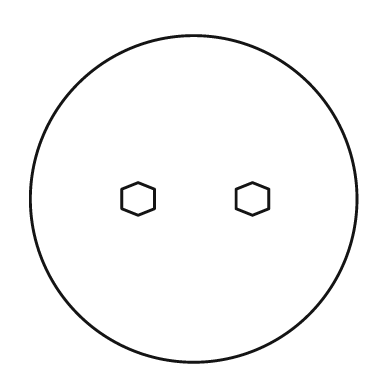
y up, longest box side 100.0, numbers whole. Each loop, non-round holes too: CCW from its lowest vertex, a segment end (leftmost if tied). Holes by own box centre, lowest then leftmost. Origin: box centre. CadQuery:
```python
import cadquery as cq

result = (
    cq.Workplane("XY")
    .moveTo(0.0, 0.0)
    .circle(50.0)
    .moveTo(-17.0, -5.0)
    .lineTo(-12.0, -3.0)
    .lineTo(-12.0, 3.0)
    .lineTo(-17.0, 5.0)
    .lineTo(-22.0, 3.0)
    .lineTo(-22.0, -3.0)
    .close()
    .moveTo(18.0, -5.0)
    .lineTo(23.0, -3.0)
    .lineTo(23.0, 3.0)
    .lineTo(18.0, 5.0)
    .lineTo(13.0, 3.0)
    .lineTo(13.0, -3.0)
    .close()
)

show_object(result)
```